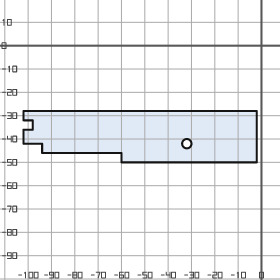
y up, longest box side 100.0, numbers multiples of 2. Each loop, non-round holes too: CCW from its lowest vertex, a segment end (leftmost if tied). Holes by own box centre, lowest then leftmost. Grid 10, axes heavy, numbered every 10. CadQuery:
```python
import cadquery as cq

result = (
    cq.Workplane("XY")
    .moveTo(-60.0, -50.0)
    .lineTo(-2.0, -50.0)
    .lineTo(-2.0, -28.0)
    .lineTo(-102.0, -28.0)
    .lineTo(-102.0, -32.0)
    .lineTo(-98.0, -32.0)
    .lineTo(-98.0, -36.0)
    .lineTo(-102.0, -36.0)
    .lineTo(-102.0, -42.0)
    .lineTo(-94.0, -42.0)
    .lineTo(-94.0, -46.0)
    .lineTo(-60.0, -46.0)
    .close()
    .moveTo(-32.0, -42.0)
    .circle(2.0)
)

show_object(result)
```